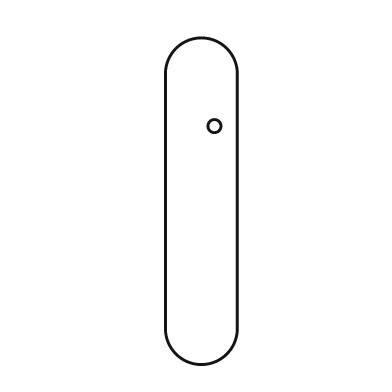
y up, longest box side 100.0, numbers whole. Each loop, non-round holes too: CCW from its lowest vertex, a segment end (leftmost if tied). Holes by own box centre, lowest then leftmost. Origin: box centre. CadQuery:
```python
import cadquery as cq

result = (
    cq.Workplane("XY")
    .moveTo(-11.0, -39.0)
    .threePointArc((0.0, -50.0), (11.0, -39.0))
    .lineTo(11.0, 39.0)
    .threePointArc((0.0, 50.0), (-11.0, 39.0))
    .close()
    .moveTo(4.0, 23.0)
    .circle(2.0)
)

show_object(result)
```